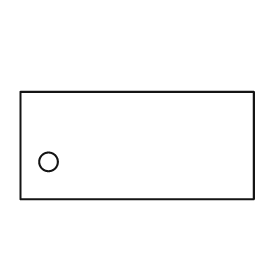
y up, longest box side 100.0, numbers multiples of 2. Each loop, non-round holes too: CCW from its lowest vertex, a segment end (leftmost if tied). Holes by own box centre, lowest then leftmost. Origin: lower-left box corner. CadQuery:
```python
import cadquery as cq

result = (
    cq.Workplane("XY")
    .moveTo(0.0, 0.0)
    .lineTo(100.0, 0.0)
    .lineTo(100.0, 46.0)
    .lineTo(0.0, 46.0)
    .close()
    .moveTo(12.0, 16.0)
    .circle(4.0)
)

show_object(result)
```